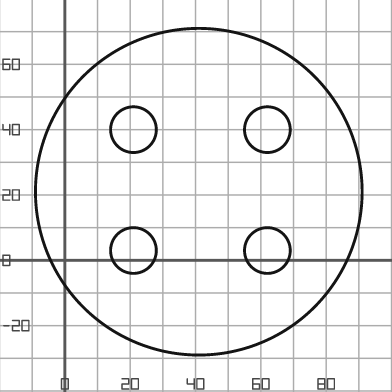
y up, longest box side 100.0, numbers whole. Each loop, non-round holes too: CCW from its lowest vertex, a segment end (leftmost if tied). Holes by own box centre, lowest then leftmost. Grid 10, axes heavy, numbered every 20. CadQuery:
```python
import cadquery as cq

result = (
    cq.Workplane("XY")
    .moveTo(41.0, 21.0)
    .circle(50.0)
    .moveTo(21.0, 3.0)
    .circle(7.0)
    .moveTo(62.0, 3.0)
    .circle(7.0)
    .moveTo(21.0, 40.0)
    .circle(7.0)
    .moveTo(62.0, 40.0)
    .circle(7.0)
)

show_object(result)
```